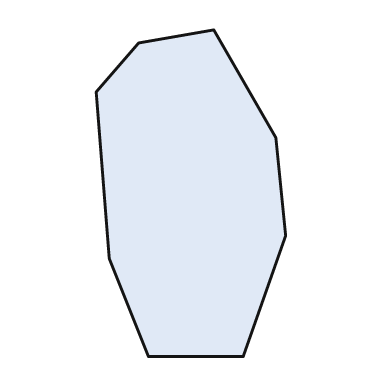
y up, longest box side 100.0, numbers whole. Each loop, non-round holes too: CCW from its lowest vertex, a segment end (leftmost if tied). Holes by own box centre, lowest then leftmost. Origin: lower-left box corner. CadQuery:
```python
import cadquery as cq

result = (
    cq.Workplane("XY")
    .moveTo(16.0, 0.0)
    .lineTo(45.0, 0.0)
    .lineTo(58.0, 37.0)
    .lineTo(55.0, 67.0)
    .lineTo(36.0, 100.0)
    .lineTo(13.0, 96.0)
    .lineTo(0.0, 81.0)
    .lineTo(4.0, 30.0)
    .close()
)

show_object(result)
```